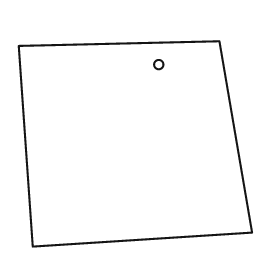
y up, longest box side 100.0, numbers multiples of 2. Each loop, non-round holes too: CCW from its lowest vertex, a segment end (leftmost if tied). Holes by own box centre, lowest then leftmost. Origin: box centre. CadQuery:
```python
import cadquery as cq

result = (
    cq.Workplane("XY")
    .moveTo(-44.0, -44.0)
    .lineTo(50.0, -38.0)
    .lineTo(36.0, 44.0)
    .lineTo(-50.0, 42.0)
    .close()
    .moveTo(10.0, 34.0)
    .circle(2.0)
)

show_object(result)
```